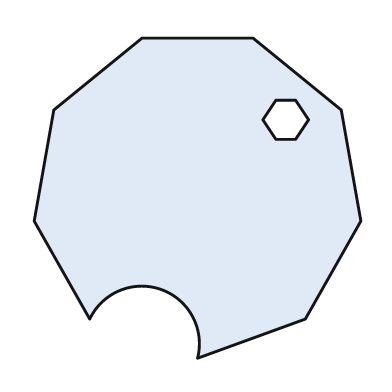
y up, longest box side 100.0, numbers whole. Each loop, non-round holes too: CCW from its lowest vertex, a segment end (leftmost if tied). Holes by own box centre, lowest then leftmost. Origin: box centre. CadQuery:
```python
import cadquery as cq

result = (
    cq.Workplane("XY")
    .moveTo(0.0, -49.0)
    .lineTo(33.0, -37.0)
    .lineTo(50.0, -7.0)
    .lineTo(44.0, 27.0)
    .lineTo(17.0, 49.0)
    .lineTo(-17.0, 49.0)
    .lineTo(-44.0, 27.0)
    .lineTo(-50.0, -7.0)
    .lineTo(-33.0, -37.0)
    .threePointArc((-11.0, -28.0), (0.0, -49.0))
    .close()
    .moveTo(24.0, 18.0)
    .lineTo(30.0, 18.0)
    .lineTo(34.0, 24.0)
    .lineTo(30.0, 30.0)
    .lineTo(24.0, 30.0)
    .lineTo(20.0, 24.0)
    .close()
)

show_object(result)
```